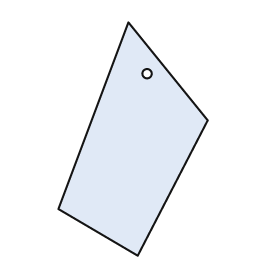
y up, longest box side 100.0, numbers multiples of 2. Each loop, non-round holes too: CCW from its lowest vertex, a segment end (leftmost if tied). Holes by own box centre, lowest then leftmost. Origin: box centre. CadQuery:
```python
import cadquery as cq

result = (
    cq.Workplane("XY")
    .moveTo(2.0, -50.0)
    .lineTo(32.0, 8.0)
    .lineTo(-2.0, 50.0)
    .lineTo(-32.0, -30.0)
    .close()
    .moveTo(6.0, 28.0)
    .circle(2.0)
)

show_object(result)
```